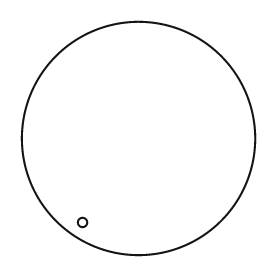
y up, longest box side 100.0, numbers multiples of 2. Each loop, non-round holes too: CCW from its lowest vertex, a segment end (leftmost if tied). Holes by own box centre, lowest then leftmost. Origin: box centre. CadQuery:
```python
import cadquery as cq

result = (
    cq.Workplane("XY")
    .moveTo(0.0, 0.0)
    .circle(50.0)
    .moveTo(-24.0, -36.0)
    .circle(2.0)
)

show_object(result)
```